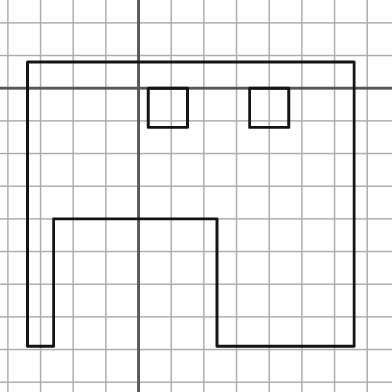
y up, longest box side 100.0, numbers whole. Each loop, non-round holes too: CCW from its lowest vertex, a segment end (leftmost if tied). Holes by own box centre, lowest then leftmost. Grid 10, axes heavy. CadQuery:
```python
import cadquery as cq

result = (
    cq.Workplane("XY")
    .moveTo(-34.0, -79.0)
    .lineTo(-26.0, -79.0)
    .lineTo(-26.0, -40.0)
    .lineTo(24.0, -40.0)
    .lineTo(24.0, -79.0)
    .lineTo(66.0, -79.0)
    .lineTo(66.0, 8.0)
    .lineTo(-34.0, 8.0)
    .close()
    .moveTo(3.0, -12.0)
    .lineTo(15.0, -12.0)
    .lineTo(15.0, 0.0)
    .lineTo(3.0, 0.0)
    .close()
    .moveTo(34.0, -12.0)
    .lineTo(46.0, -12.0)
    .lineTo(46.0, 0.0)
    .lineTo(34.0, 0.0)
    .close()
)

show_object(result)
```